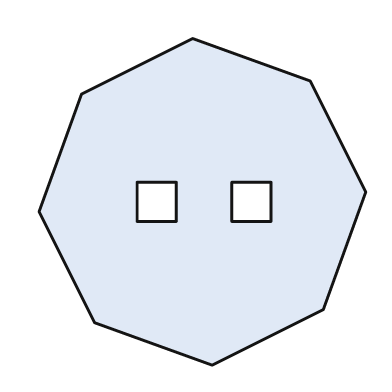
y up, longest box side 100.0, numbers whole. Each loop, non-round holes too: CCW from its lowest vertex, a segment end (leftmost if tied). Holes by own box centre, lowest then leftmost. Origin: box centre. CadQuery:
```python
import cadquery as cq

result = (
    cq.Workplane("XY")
    .moveTo(3.0, -50.0)
    .lineTo(37.0, -33.0)
    .lineTo(50.0, 3.0)
    .lineTo(33.0, 37.0)
    .lineTo(-3.0, 50.0)
    .lineTo(-37.0, 33.0)
    .lineTo(-50.0, -3.0)
    .lineTo(-33.0, -37.0)
    .close()
    .moveTo(-20.0, -6.0)
    .lineTo(-8.0, -6.0)
    .lineTo(-8.0, 6.0)
    .lineTo(-20.0, 6.0)
    .close()
    .moveTo(9.0, -6.0)
    .lineTo(21.0, -6.0)
    .lineTo(21.0, 6.0)
    .lineTo(9.0, 6.0)
    .close()
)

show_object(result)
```